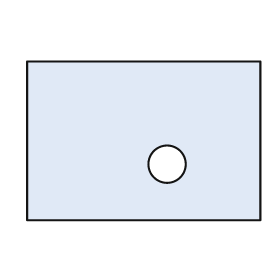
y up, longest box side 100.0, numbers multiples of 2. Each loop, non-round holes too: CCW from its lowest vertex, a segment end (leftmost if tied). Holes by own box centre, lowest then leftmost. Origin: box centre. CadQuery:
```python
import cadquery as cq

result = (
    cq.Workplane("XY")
    .moveTo(-50.0, -34.0)
    .lineTo(50.0, -34.0)
    .lineTo(50.0, 34.0)
    .lineTo(-50.0, 34.0)
    .close()
    .moveTo(10.0, -10.0)
    .circle(8.0)
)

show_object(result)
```